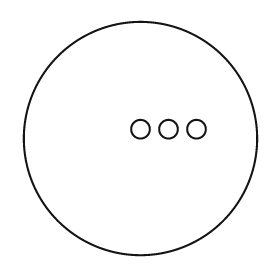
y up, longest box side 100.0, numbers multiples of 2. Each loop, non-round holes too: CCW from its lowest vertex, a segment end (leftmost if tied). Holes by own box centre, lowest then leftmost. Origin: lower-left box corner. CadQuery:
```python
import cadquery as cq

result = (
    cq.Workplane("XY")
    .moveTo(50.0, 50.0)
    .circle(50.0)
    .moveTo(50.0, 54.0)
    .circle(4.0)
    .moveTo(62.0, 54.0)
    .circle(4.0)
    .moveTo(74.0, 54.0)
    .circle(4.0)
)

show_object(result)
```